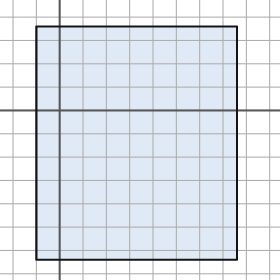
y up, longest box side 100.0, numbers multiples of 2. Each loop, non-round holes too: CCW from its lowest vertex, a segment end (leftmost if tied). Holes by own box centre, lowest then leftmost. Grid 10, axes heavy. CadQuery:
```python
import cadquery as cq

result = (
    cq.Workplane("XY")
    .moveTo(-10.0, -64.0)
    .lineTo(76.0, -64.0)
    .lineTo(76.0, 36.0)
    .lineTo(-10.0, 36.0)
    .close()
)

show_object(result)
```